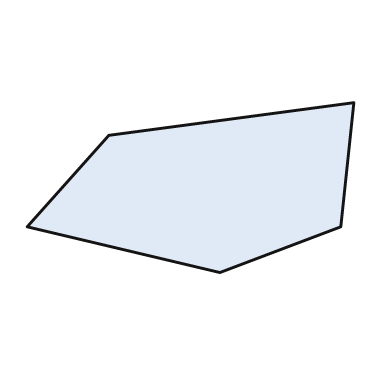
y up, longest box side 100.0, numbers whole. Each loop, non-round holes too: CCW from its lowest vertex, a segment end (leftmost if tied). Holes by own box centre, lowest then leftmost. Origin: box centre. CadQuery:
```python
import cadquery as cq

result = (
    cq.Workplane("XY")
    .moveTo(9.0, -26.0)
    .lineTo(46.0, -12.0)
    .lineTo(50.0, 26.0)
    .lineTo(-25.0, 16.0)
    .lineTo(-50.0, -12.0)
    .close()
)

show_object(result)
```